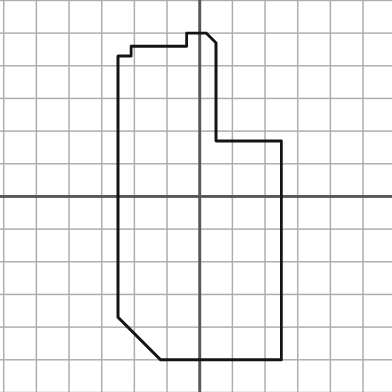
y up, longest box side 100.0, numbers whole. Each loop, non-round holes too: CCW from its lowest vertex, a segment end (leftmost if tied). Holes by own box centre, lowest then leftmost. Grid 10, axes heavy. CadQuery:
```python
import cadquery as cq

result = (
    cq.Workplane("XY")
    .moveTo(-12.0, -50.0)
    .lineTo(25.0, -50.0)
    .lineTo(25.0, 17.0)
    .lineTo(5.0, 17.0)
    .lineTo(5.0, 47.0)
    .lineTo(2.0, 50.0)
    .lineTo(-4.0, 50.0)
    .lineTo(-4.0, 46.0)
    .lineTo(-21.0, 46.0)
    .lineTo(-21.0, 43.0)
    .lineTo(-25.0, 43.0)
    .lineTo(-25.0, -37.0)
    .close()
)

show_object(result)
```